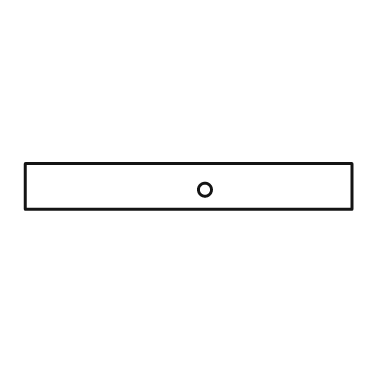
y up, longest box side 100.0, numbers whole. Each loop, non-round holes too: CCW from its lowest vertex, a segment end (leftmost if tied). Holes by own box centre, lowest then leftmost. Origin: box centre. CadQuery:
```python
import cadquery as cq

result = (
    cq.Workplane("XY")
    .moveTo(-50.0, -7.0)
    .lineTo(50.0, -7.0)
    .lineTo(50.0, 7.0)
    .lineTo(-50.0, 7.0)
    .close()
    .moveTo(5.0, -1.0)
    .circle(2.0)
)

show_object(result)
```